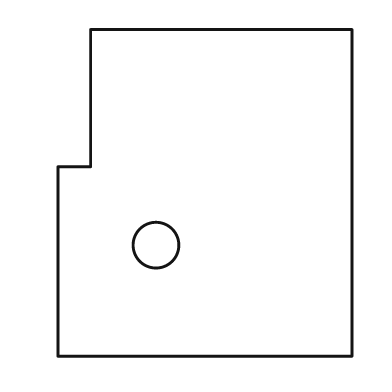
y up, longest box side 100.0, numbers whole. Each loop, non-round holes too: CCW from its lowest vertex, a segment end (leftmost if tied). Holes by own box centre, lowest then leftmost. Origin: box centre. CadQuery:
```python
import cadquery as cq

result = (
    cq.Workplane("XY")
    .moveTo(-45.0, -50.0)
    .lineTo(45.0, -50.0)
    .lineTo(45.0, 50.0)
    .lineTo(-35.0, 50.0)
    .lineTo(-35.0, 8.0)
    .lineTo(-45.0, 8.0)
    .close()
    .moveTo(-15.0, -16.0)
    .circle(7.0)
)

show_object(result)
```